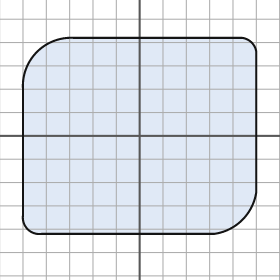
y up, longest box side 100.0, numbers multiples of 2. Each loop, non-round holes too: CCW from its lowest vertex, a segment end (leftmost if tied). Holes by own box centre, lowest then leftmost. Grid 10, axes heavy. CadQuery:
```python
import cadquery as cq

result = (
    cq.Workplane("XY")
    .moveTo(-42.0, -42.0)
    .lineTo(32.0, -42.0)
    .threePointArc((44.0, -36.0), (50.0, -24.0))
    .lineTo(50.0, 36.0)
    .threePointArc((48.0, 40.0), (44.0, 42.0))
    .lineTo(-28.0, 42.0)
    .threePointArc((-44.0, 36.0), (-50.0, 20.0))
    .lineTo(-50.0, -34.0)
    .threePointArc((-48.0, -40.0), (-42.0, -42.0))
    .close()
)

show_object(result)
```